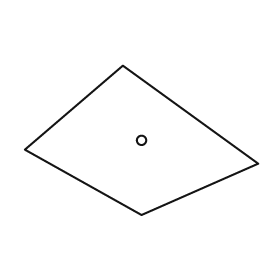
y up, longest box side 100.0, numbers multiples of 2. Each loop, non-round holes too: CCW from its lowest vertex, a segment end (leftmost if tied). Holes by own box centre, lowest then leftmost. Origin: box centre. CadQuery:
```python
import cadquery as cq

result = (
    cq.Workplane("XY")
    .moveTo(0.0, -32.0)
    .lineTo(50.0, -10.0)
    .lineTo(-8.0, 32.0)
    .lineTo(-50.0, -4.0)
    .close()
    .moveTo(0.0, 0.0)
    .circle(2.0)
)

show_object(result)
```